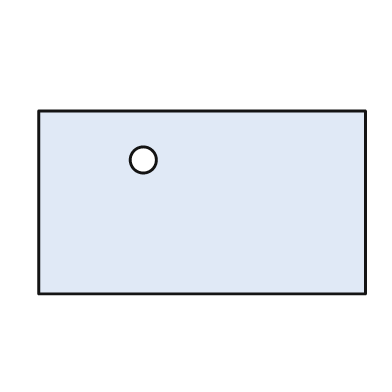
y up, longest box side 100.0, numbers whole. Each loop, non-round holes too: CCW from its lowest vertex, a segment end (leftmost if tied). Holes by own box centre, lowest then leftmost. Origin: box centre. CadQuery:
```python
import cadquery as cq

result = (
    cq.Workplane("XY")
    .moveTo(-50.0, -28.0)
    .lineTo(50.0, -28.0)
    .lineTo(50.0, 28.0)
    .lineTo(-50.0, 28.0)
    .close()
    .moveTo(-18.0, 13.0)
    .circle(4.0)
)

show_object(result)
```